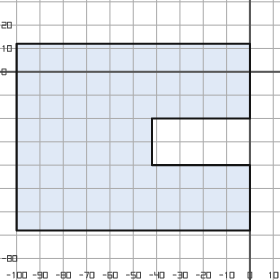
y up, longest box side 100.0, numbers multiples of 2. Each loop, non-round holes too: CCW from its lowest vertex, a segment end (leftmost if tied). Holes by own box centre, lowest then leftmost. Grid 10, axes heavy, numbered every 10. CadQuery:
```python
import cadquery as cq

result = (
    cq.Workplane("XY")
    .moveTo(-100.0, -68.0)
    .lineTo(0.0, -68.0)
    .lineTo(0.0, -40.0)
    .lineTo(-42.0, -40.0)
    .lineTo(-42.0, -20.0)
    .lineTo(0.0, -20.0)
    .lineTo(0.0, 12.0)
    .lineTo(-100.0, 12.0)
    .close()
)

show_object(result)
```